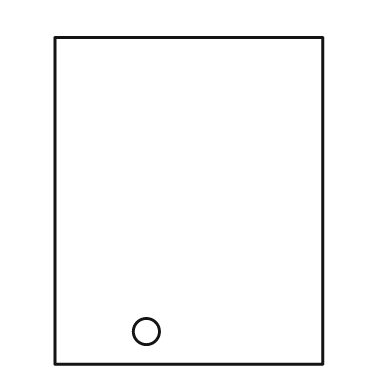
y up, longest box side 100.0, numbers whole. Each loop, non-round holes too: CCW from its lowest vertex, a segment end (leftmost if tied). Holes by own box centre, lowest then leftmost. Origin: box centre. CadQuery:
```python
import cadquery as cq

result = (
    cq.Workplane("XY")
    .moveTo(-41.0, -50.0)
    .lineTo(41.0, -50.0)
    .lineTo(41.0, 50.0)
    .lineTo(-41.0, 50.0)
    .close()
    .moveTo(-13.0, -40.0)
    .circle(4.0)
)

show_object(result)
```